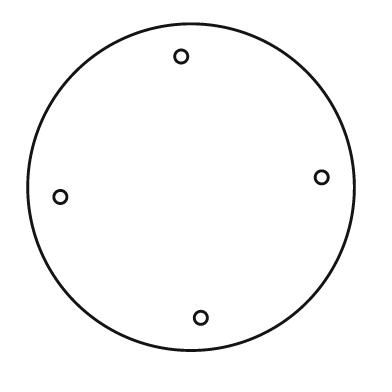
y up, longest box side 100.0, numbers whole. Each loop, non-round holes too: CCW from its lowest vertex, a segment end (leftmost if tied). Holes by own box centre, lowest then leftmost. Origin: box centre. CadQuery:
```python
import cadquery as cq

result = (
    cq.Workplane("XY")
    .moveTo(0.0, 0.0)
    .circle(50.0)
    .moveTo(3.0, -40.0)
    .circle(2.0)
    .moveTo(-40.0, -3.0)
    .circle(2.0)
    .moveTo(40.0, 3.0)
    .circle(2.0)
    .moveTo(-3.0, 40.0)
    .circle(2.0)
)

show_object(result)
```